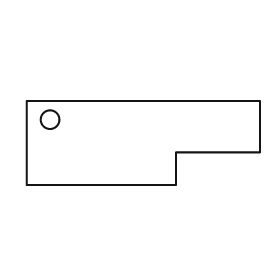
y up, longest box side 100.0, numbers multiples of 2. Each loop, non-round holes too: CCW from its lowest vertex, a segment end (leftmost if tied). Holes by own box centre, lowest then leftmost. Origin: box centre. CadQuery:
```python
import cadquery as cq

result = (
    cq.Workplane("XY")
    .moveTo(-50.0, -18.0)
    .lineTo(14.0, -18.0)
    .lineTo(14.0, -4.0)
    .lineTo(50.0, -4.0)
    .lineTo(50.0, 18.0)
    .lineTo(-50.0, 18.0)
    .close()
    .moveTo(-40.0, 10.0)
    .circle(4.0)
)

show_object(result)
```